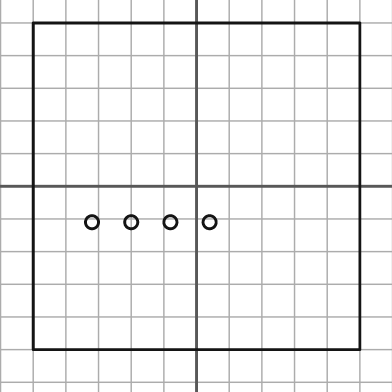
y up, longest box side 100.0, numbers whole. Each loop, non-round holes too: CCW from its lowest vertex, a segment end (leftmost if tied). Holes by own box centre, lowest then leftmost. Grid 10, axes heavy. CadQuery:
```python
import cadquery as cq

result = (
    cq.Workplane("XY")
    .moveTo(-50.0, -50.0)
    .lineTo(50.0, -50.0)
    .lineTo(50.0, 50.0)
    .lineTo(-50.0, 50.0)
    .close()
    .moveTo(-32.0, -11.0)
    .circle(2.0)
    .moveTo(-20.0, -11.0)
    .circle(2.0)
    .moveTo(-8.0, -11.0)
    .circle(2.0)
    .moveTo(4.0, -11.0)
    .circle(2.0)
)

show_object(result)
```